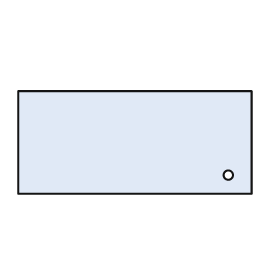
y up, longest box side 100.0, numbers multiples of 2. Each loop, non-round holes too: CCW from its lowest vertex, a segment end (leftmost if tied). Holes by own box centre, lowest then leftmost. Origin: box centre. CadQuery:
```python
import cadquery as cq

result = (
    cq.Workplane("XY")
    .moveTo(-50.0, -22.0)
    .lineTo(50.0, -22.0)
    .lineTo(50.0, 22.0)
    .lineTo(-50.0, 22.0)
    .close()
    .moveTo(40.0, -14.0)
    .circle(2.0)
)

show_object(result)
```